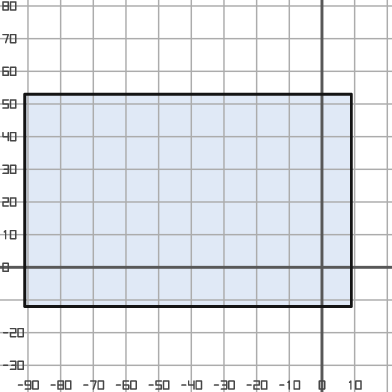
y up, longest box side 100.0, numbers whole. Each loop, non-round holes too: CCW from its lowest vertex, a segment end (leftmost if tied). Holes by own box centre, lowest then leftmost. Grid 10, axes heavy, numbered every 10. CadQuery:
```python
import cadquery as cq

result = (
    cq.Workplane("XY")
    .moveTo(-91.0, -12.0)
    .lineTo(9.0, -12.0)
    .lineTo(9.0, 53.0)
    .lineTo(-91.0, 53.0)
    .close()
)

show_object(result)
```